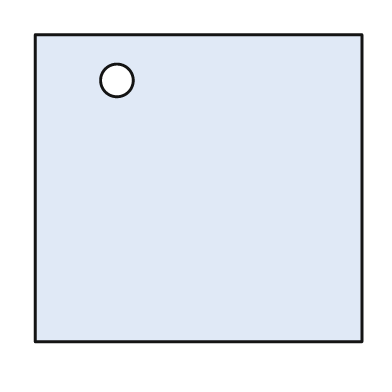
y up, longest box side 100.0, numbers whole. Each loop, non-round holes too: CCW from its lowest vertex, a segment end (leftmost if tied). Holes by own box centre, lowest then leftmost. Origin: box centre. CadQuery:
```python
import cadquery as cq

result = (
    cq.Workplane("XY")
    .moveTo(-50.0, -47.0)
    .lineTo(50.0, -47.0)
    .lineTo(50.0, 47.0)
    .lineTo(-50.0, 47.0)
    .close()
    .moveTo(-25.0, 33.0)
    .circle(5.0)
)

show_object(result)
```